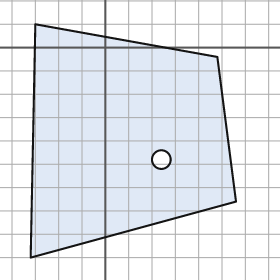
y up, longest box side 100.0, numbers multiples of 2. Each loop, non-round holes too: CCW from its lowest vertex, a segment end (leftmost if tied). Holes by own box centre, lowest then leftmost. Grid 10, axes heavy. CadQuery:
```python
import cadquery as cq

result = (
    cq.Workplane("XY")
    .moveTo(-32.0, -90.0)
    .lineTo(56.0, -66.0)
    .lineTo(48.0, -4.0)
    .lineTo(-30.0, 10.0)
    .close()
    .moveTo(24.0, -48.0)
    .circle(4.0)
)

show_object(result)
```